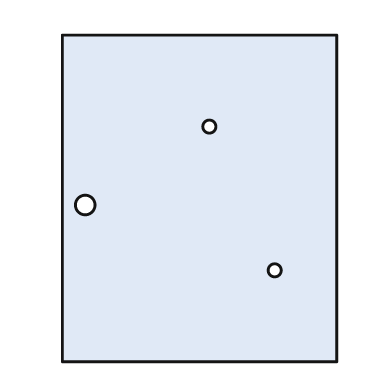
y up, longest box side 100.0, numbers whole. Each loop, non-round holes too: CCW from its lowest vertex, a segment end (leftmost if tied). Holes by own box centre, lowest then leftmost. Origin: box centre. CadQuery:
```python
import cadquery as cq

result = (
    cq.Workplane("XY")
    .moveTo(-42.0, -50.0)
    .lineTo(42.0, -50.0)
    .lineTo(42.0, 50.0)
    .lineTo(-42.0, 50.0)
    .close()
    .moveTo(23.0, -22.0)
    .circle(2.0)
    .moveTo(-35.0, -2.0)
    .circle(3.0)
    .moveTo(3.0, 22.0)
    .circle(2.0)
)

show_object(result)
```